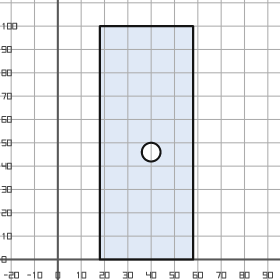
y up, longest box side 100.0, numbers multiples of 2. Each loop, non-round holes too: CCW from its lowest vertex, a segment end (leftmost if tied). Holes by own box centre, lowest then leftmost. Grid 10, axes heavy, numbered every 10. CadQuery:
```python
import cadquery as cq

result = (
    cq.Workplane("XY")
    .moveTo(18.0, 0.0)
    .lineTo(58.0, 0.0)
    .lineTo(58.0, 100.0)
    .lineTo(18.0, 100.0)
    .close()
    .moveTo(40.0, 46.0)
    .circle(4.0)
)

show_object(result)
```